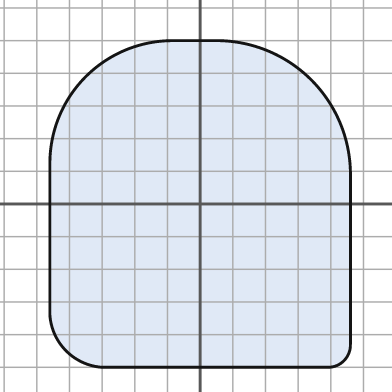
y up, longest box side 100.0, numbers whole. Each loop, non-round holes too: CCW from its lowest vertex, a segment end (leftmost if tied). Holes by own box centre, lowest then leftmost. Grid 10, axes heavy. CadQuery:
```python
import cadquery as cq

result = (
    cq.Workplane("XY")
    .moveTo(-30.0, -50.0)
    .lineTo(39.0, -50.0)
    .threePointArc((44.0, -48.0), (46.0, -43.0))
    .lineTo(46.0, 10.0)
    .threePointArc((34.0, 38.0), (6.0, 50.0))
    .lineTo(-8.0, 50.0)
    .threePointArc((-35.0, 39.0), (-46.0, 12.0))
    .lineTo(-46.0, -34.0)
    .threePointArc((-41.0, -45.0), (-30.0, -50.0))
    .close()
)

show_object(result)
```